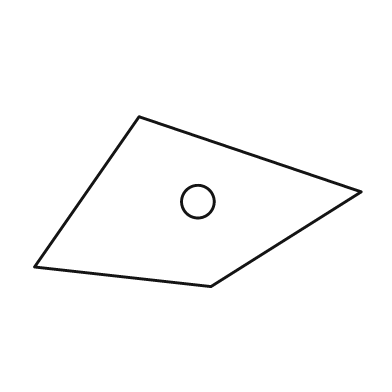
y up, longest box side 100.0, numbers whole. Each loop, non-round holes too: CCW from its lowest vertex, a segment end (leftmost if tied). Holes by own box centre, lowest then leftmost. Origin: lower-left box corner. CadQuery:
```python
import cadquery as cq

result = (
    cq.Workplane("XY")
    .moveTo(54.0, 0.0)
    .lineTo(100.0, 29.0)
    .lineTo(32.0, 52.0)
    .lineTo(0.0, 6.0)
    .close()
    .moveTo(50.0, 26.0)
    .circle(5.0)
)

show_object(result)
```